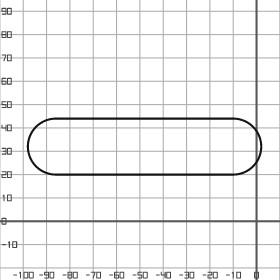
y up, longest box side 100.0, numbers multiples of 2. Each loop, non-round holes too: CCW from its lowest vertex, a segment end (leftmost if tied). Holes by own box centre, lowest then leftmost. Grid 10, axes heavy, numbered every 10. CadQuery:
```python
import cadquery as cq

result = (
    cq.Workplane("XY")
    .moveTo(-86.0, 20.0)
    .lineTo(-10.0, 20.0)
    .threePointArc((2.0, 32.0), (-10.0, 44.0))
    .lineTo(-86.0, 44.0)
    .threePointArc((-98.0, 32.0), (-86.0, 20.0))
    .close()
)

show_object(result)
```